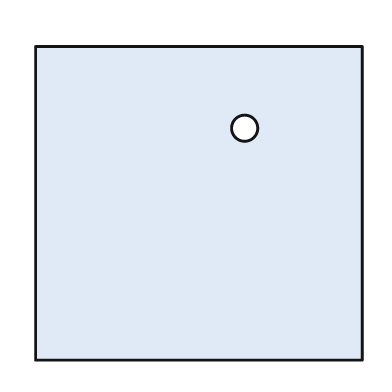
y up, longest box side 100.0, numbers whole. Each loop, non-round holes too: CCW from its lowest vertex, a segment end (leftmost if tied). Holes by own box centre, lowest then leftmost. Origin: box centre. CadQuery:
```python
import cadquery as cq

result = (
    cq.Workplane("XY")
    .moveTo(-50.0, -48.0)
    .lineTo(50.0, -48.0)
    .lineTo(50.0, 48.0)
    .lineTo(-50.0, 48.0)
    .close()
    .moveTo(14.0, 23.0)
    .circle(4.0)
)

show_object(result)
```